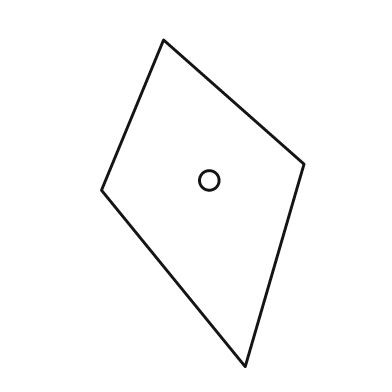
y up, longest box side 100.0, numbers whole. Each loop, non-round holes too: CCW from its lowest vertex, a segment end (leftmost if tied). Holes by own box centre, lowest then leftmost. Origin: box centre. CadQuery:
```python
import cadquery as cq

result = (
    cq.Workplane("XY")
    .moveTo(13.0, -50.0)
    .lineTo(31.0, 12.0)
    .lineTo(-12.0, 50.0)
    .lineTo(-31.0, 4.0)
    .close()
    .moveTo(2.0, 7.0)
    .circle(3.0)
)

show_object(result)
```